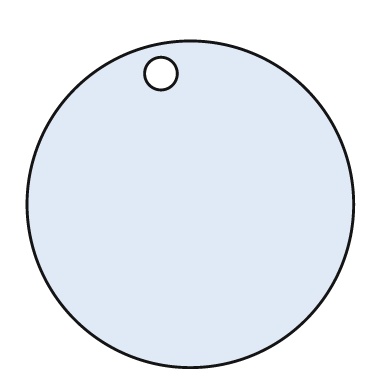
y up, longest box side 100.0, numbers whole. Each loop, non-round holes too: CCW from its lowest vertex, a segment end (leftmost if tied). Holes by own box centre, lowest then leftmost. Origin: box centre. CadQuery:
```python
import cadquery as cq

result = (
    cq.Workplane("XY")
    .moveTo(0.0, 0.0)
    .circle(50.0)
    .moveTo(-9.0, 40.0)
    .circle(5.0)
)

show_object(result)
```